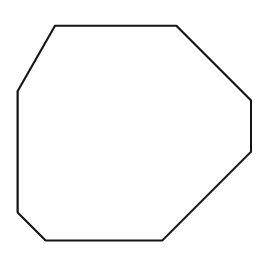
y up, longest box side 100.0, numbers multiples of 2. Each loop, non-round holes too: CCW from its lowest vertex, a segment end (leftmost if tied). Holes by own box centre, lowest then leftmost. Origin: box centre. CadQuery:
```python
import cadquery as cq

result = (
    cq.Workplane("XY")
    .moveTo(-38.0, -46.0)
    .lineTo(12.0, -46.0)
    .lineTo(50.0, -8.0)
    .lineTo(50.0, 14.0)
    .lineTo(18.0, 46.0)
    .lineTo(-34.0, 46.0)
    .lineTo(-50.0, 18.0)
    .lineTo(-50.0, -34.0)
    .close()
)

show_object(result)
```